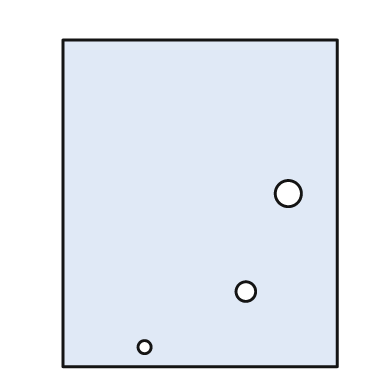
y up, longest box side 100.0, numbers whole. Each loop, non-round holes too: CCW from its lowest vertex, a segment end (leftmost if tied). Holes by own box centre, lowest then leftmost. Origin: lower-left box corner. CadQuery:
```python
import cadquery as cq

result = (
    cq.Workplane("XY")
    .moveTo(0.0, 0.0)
    .lineTo(84.0, 0.0)
    .lineTo(84.0, 100.0)
    .lineTo(0.0, 100.0)
    .close()
    .moveTo(25.0, 6.0)
    .circle(2.0)
    .moveTo(56.0, 23.0)
    .circle(3.0)
    .moveTo(69.0, 53.0)
    .circle(4.0)
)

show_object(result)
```